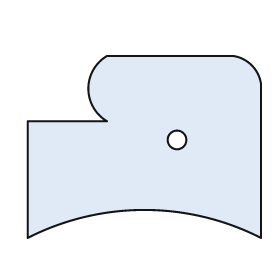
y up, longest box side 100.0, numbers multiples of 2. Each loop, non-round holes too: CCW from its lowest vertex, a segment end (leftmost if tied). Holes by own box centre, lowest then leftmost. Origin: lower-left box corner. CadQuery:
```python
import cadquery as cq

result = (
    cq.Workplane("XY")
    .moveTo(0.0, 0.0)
    .threePointArc((50.0, 12.0), (100.0, 0.0))
    .lineTo(100.0, 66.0)
    .threePointArc((96.0, 74.0), (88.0, 78.0))
    .lineTo(34.0, 78.0)
    .threePointArc((26.0, 64.0), (34.0, 50.0))
    .lineTo(0.0, 50.0)
    .close()
    .moveTo(64.0, 42.0)
    .circle(4.0)
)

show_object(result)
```